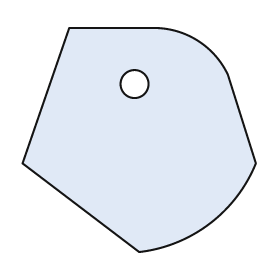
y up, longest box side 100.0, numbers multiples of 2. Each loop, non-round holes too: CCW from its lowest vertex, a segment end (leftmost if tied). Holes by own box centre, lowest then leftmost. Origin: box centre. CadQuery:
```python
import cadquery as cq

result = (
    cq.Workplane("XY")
    .moveTo(0.0, -48.0)
    .threePointArc((30.0, -36.0), (50.0, -10.0))
    .lineTo(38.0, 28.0)
    .threePointArc((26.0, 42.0), (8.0, 48.0))
    .lineTo(-30.0, 48.0)
    .lineTo(-50.0, -10.0)
    .close()
    .moveTo(-2.0, 24.0)
    .circle(6.0)
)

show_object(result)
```